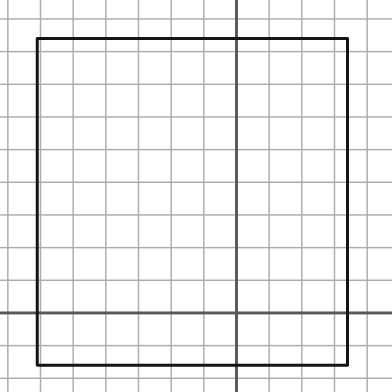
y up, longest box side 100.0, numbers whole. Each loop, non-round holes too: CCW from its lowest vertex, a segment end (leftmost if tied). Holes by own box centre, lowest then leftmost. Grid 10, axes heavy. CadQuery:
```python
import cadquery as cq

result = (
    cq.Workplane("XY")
    .moveTo(-61.0, -16.0)
    .lineTo(34.0, -16.0)
    .lineTo(34.0, 84.0)
    .lineTo(-61.0, 84.0)
    .close()
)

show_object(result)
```